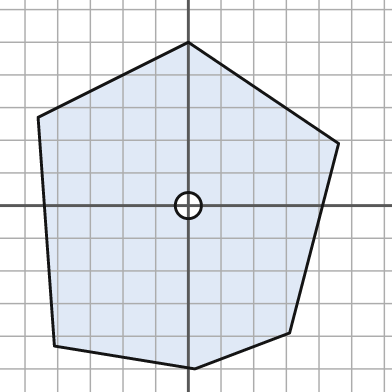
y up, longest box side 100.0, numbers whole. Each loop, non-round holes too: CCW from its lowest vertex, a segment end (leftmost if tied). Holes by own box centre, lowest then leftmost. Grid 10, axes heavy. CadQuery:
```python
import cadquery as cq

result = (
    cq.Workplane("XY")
    .moveTo(2.0, -50.0)
    .lineTo(31.0, -39.0)
    .lineTo(46.0, 19.0)
    .lineTo(0.0, 50.0)
    .lineTo(-46.0, 27.0)
    .lineTo(-41.0, -43.0)
    .close()
    .moveTo(0.0, 0.0)
    .circle(4.0)
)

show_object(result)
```